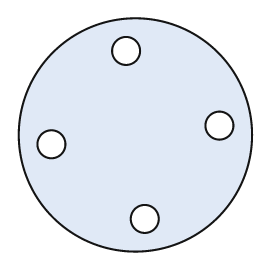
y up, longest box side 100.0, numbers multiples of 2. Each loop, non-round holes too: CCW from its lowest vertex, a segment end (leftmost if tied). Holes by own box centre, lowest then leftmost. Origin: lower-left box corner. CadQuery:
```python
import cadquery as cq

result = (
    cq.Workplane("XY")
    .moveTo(50.0, 50.0)
    .circle(50.0)
    .moveTo(54.0, 14.0)
    .circle(6.0)
    .moveTo(14.0, 46.0)
    .circle(6.0)
    .moveTo(86.0, 54.0)
    .circle(6.0)
    .moveTo(46.0, 86.0)
    .circle(6.0)
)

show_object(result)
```